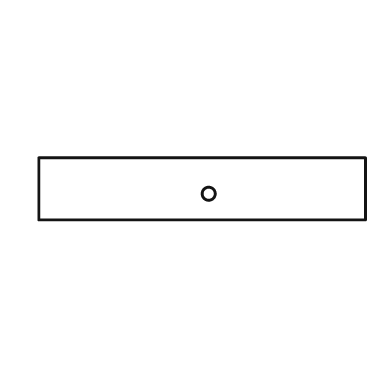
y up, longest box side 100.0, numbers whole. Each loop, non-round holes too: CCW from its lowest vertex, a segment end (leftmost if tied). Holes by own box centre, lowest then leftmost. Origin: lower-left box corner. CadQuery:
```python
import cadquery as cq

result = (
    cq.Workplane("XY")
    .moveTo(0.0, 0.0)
    .lineTo(100.0, 0.0)
    .lineTo(100.0, 19.0)
    .lineTo(0.0, 19.0)
    .close()
    .moveTo(52.0, 8.0)
    .circle(2.0)
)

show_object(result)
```